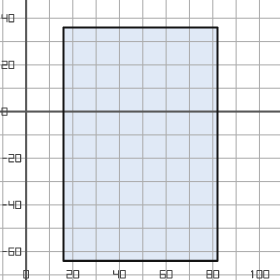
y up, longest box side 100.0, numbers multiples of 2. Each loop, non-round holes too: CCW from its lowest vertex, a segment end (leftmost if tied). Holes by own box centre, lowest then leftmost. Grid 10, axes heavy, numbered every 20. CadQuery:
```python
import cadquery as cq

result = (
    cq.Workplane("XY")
    .moveTo(16.0, -64.0)
    .lineTo(82.0, -64.0)
    .lineTo(82.0, 36.0)
    .lineTo(16.0, 36.0)
    .close()
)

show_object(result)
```